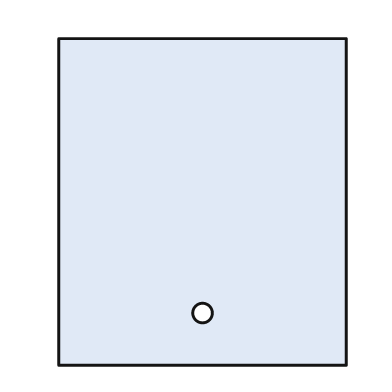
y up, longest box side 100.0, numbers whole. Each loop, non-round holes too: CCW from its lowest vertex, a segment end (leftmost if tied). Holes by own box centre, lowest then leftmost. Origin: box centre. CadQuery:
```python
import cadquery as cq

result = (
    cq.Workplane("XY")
    .moveTo(-44.0, -50.0)
    .lineTo(44.0, -50.0)
    .lineTo(44.0, 50.0)
    .lineTo(-44.0, 50.0)
    .close()
    .moveTo(0.0, -34.0)
    .circle(3.0)
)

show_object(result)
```